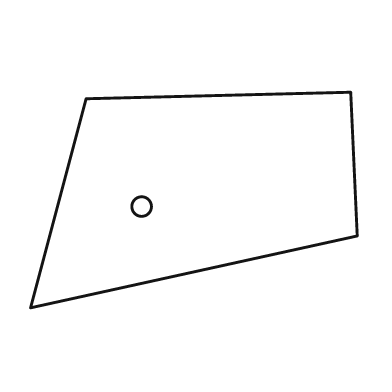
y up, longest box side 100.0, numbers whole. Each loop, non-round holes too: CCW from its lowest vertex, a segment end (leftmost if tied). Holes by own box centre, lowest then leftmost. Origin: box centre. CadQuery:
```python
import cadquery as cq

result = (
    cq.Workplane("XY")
    .moveTo(-50.0, -33.0)
    .lineTo(50.0, -11.0)
    .lineTo(48.0, 33.0)
    .lineTo(-33.0, 31.0)
    .close()
    .moveTo(-16.0, -2.0)
    .circle(3.0)
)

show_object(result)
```